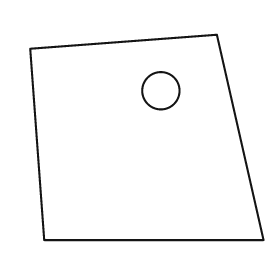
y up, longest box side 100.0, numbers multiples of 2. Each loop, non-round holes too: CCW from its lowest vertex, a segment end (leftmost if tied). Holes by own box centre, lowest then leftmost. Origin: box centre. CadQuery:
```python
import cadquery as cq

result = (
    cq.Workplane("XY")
    .moveTo(-44.0, -44.0)
    .lineTo(50.0, -44.0)
    .lineTo(30.0, 44.0)
    .lineTo(-50.0, 38.0)
    .close()
    .moveTo(6.0, 20.0)
    .circle(8.0)
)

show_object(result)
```